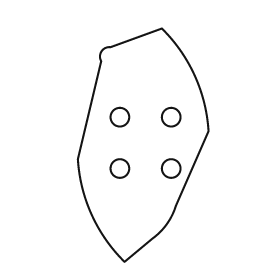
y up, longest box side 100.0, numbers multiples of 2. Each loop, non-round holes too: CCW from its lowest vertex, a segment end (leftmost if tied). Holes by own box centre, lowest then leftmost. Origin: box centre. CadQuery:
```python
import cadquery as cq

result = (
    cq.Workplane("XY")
    .moveTo(-8.0, -50.0)
    .lineTo(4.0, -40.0)
    .threePointArc((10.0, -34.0), (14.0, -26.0))
    .lineTo(28.0, 6.0)
    .threePointArc((22.0, 30.0), (8.0, 50.0))
    .lineTo(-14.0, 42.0)
    .threePointArc((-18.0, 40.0), (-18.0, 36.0))
    .lineTo(-28.0, -6.0)
    .threePointArc((-22.0, -30.0), (-8.0, -50.0))
    .close()
    .moveTo(-10.0, -10.0)
    .circle(4.0)
    .moveTo(12.0, -10.0)
    .circle(4.0)
    .moveTo(-10.0, 12.0)
    .circle(4.0)
    .moveTo(12.0, 12.0)
    .circle(4.0)
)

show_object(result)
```